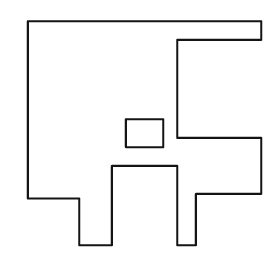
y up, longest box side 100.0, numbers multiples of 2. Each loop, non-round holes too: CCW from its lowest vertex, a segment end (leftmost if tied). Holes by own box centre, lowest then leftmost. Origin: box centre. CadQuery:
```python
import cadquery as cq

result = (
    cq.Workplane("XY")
    .moveTo(-28.0, -48.0)
    .lineTo(-14.0, -48.0)
    .lineTo(-14.0, -14.0)
    .lineTo(14.0, -14.0)
    .lineTo(14.0, -48.0)
    .lineTo(22.0, -48.0)
    .lineTo(22.0, -26.0)
    .lineTo(50.0, -26.0)
    .lineTo(50.0, -2.0)
    .lineTo(14.0, -2.0)
    .lineTo(14.0, 40.0)
    .lineTo(50.0, 40.0)
    .lineTo(50.0, 48.0)
    .lineTo(-50.0, 48.0)
    .lineTo(-50.0, -28.0)
    .lineTo(-28.0, -28.0)
    .close()
    .moveTo(-8.0, -6.0)
    .lineTo(8.0, -6.0)
    .lineTo(8.0, 6.0)
    .lineTo(-8.0, 6.0)
    .close()
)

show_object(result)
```